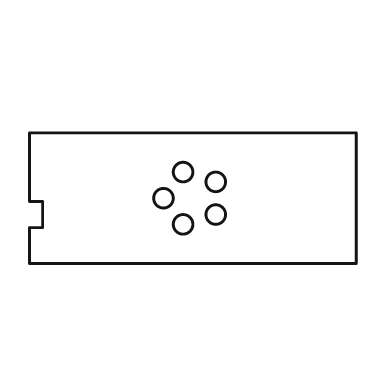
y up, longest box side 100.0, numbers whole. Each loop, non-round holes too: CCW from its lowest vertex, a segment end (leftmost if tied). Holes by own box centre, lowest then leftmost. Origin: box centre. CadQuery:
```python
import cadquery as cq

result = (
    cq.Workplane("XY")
    .moveTo(-50.0, -20.0)
    .lineTo(50.0, -20.0)
    .lineTo(50.0, 20.0)
    .lineTo(-50.0, 20.0)
    .lineTo(-50.0, -1.0)
    .lineTo(-46.0, -1.0)
    .lineTo(-46.0, -9.0)
    .lineTo(-50.0, -9.0)
    .close()
    .moveTo(-3.0, -8.0)
    .circle(3.0)
    .moveTo(7.0, -5.0)
    .circle(3.0)
    .moveTo(-9.0, 0.0)
    .circle(3.0)
    .moveTo(7.0, 5.0)
    .circle(3.0)
    .moveTo(-3.0, 8.0)
    .circle(3.0)
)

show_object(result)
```